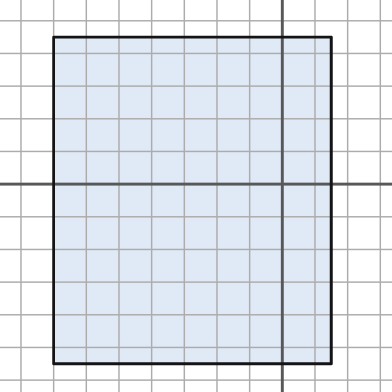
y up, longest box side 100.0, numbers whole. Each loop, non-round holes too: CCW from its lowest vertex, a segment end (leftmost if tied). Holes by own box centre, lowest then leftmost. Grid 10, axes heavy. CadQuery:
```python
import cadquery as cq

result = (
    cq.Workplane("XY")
    .moveTo(-70.0, -55.0)
    .lineTo(15.0, -55.0)
    .lineTo(15.0, 45.0)
    .lineTo(-70.0, 45.0)
    .close()
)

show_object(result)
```